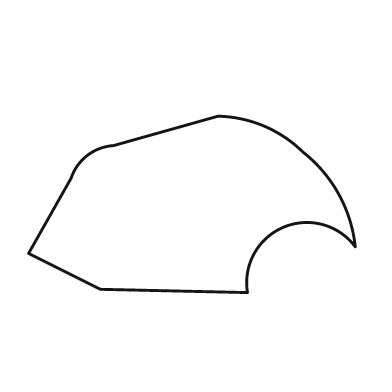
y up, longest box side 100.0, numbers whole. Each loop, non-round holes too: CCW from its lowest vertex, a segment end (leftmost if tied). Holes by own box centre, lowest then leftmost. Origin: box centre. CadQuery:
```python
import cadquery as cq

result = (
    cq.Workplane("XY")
    .moveTo(17.0, -27.0)
    .threePointArc((28.0, -7.0), (50.0, -13.0))
    .threePointArc((45.0, 3.0), (34.0, 16.0))
    .threePointArc((22.0, 24.0), (8.0, 27.0))
    .lineTo(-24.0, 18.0)
    .threePointArc((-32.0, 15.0), (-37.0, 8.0))
    .lineTo(-50.0, -15.0)
    .lineTo(-28.0, -26.0)
    .close()
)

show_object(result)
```